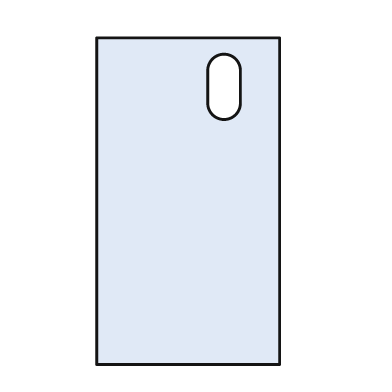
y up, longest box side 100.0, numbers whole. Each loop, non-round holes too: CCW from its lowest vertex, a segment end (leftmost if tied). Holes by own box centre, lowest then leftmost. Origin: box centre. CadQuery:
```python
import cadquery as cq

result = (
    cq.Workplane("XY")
    .moveTo(-28.0, -50.0)
    .lineTo(28.0, -50.0)
    .lineTo(28.0, 50.0)
    .lineTo(-28.0, 50.0)
    .close()
    .moveTo(6.0, 30.0)
    .threePointArc((11.0, 25.0), (16.0, 30.0))
    .lineTo(16.0, 40.0)
    .threePointArc((11.0, 45.0), (6.0, 40.0))
    .close()
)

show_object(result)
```